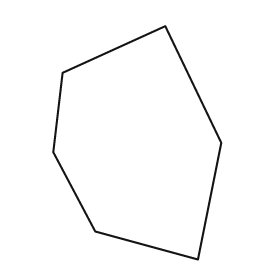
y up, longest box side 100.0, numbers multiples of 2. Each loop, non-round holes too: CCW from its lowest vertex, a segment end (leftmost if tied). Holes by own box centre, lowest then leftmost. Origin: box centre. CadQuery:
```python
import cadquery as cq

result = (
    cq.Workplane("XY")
    .moveTo(26.0, -50.0)
    .lineTo(36.0, 0.0)
    .lineTo(12.0, 50.0)
    .lineTo(-32.0, 30.0)
    .lineTo(-36.0, -4.0)
    .lineTo(-18.0, -38.0)
    .close()
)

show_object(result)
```